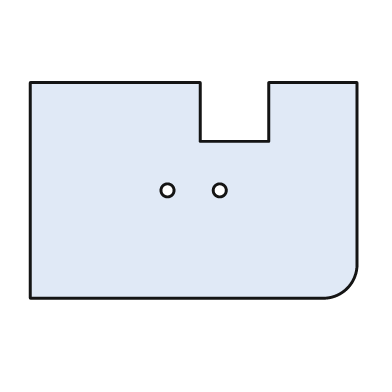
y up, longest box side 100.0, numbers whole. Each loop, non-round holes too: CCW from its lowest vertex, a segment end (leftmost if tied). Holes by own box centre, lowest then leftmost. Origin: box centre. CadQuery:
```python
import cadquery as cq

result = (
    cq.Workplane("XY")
    .moveTo(-50.0, -33.0)
    .lineTo(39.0, -33.0)
    .threePointArc((47.0, -30.0), (50.0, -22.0))
    .lineTo(50.0, 33.0)
    .lineTo(23.0, 33.0)
    .lineTo(23.0, 15.0)
    .lineTo(2.0, 15.0)
    .lineTo(2.0, 33.0)
    .lineTo(-50.0, 33.0)
    .close()
    .moveTo(-8.0, 0.0)
    .circle(2.0)
    .moveTo(8.0, 0.0)
    .circle(2.0)
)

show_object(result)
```